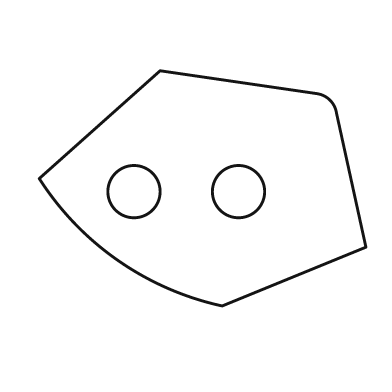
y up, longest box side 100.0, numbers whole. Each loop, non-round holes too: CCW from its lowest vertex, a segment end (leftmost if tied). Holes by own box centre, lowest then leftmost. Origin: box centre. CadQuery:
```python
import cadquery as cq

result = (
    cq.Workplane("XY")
    .moveTo(6.0, -36.0)
    .lineTo(50.0, -18.0)
    .lineTo(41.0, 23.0)
    .threePointArc((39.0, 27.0), (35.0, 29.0))
    .lineTo(-13.0, 36.0)
    .lineTo(-50.0, 3.0)
    .threePointArc((-26.0, -22.0), (6.0, -36.0))
    .close()
    .moveTo(-21.0, -1.0)
    .circle(8.0)
    .moveTo(11.0, -1.0)
    .circle(8.0)
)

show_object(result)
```